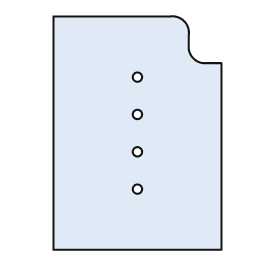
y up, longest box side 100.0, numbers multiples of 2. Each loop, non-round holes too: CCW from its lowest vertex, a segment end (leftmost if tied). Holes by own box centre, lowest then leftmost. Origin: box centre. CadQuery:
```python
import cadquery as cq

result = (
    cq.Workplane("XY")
    .moveTo(-36.0, -50.0)
    .lineTo(36.0, -50.0)
    .lineTo(36.0, 30.0)
    .lineTo(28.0, 30.0)
    .threePointArc((24.0, 32.0), (22.0, 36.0))
    .lineTo(22.0, 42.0)
    .threePointArc((20.0, 48.0), (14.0, 50.0))
    .lineTo(-36.0, 50.0)
    .close()
    .moveTo(0.0, -24.0)
    .circle(2.0)
    .moveTo(0.0, -8.0)
    .circle(2.0)
    .moveTo(0.0, 8.0)
    .circle(2.0)
    .moveTo(0.0, 24.0)
    .circle(2.0)
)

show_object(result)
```